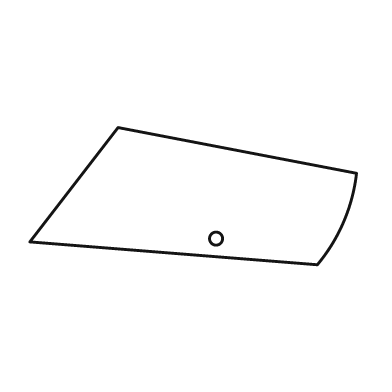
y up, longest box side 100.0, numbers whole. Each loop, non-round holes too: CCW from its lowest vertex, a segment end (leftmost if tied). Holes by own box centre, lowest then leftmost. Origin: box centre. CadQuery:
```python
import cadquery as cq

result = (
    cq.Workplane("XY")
    .moveTo(38.0, -21.0)
    .threePointArc((46.0, -8.0), (50.0, 7.0))
    .lineTo(-23.0, 21.0)
    .lineTo(-50.0, -14.0)
    .close()
    .moveTo(7.0, -13.0)
    .circle(2.0)
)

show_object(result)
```